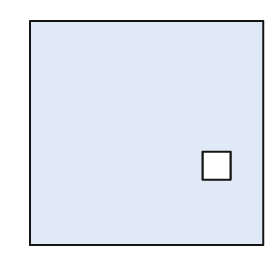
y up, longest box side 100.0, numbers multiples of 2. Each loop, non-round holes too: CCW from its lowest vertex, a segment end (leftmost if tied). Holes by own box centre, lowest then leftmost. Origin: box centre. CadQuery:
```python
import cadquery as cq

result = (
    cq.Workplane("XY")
    .moveTo(-50.0, -48.0)
    .lineTo(50.0, -48.0)
    .lineTo(50.0, 48.0)
    .lineTo(-50.0, 48.0)
    .close()
    .moveTo(24.0, -20.0)
    .lineTo(36.0, -20.0)
    .lineTo(36.0, -8.0)
    .lineTo(24.0, -8.0)
    .close()
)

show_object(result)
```